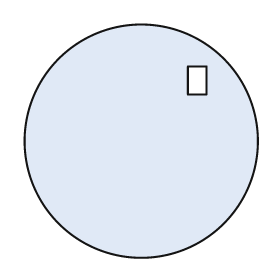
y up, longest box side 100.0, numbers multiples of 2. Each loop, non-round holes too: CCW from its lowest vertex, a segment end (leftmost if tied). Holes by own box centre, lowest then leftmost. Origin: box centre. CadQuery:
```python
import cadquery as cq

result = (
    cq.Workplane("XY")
    .moveTo(0.0, 0.0)
    .circle(50.0)
    .moveTo(20.0, 20.0)
    .lineTo(28.0, 20.0)
    .lineTo(28.0, 32.0)
    .lineTo(20.0, 32.0)
    .close()
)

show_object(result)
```